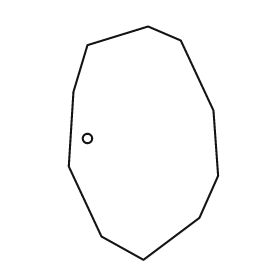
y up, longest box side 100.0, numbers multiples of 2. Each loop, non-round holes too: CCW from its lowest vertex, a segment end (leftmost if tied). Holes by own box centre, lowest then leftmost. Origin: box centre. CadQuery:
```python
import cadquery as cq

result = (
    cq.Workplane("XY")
    .moveTo(0.0, -50.0)
    .lineTo(24.0, -32.0)
    .lineTo(32.0, -14.0)
    .lineTo(30.0, 14.0)
    .lineTo(16.0, 44.0)
    .lineTo(2.0, 50.0)
    .lineTo(-24.0, 42.0)
    .lineTo(-30.0, 22.0)
    .lineTo(-32.0, -10.0)
    .lineTo(-18.0, -40.0)
    .close()
    .moveTo(-24.0, 2.0)
    .circle(2.0)
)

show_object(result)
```